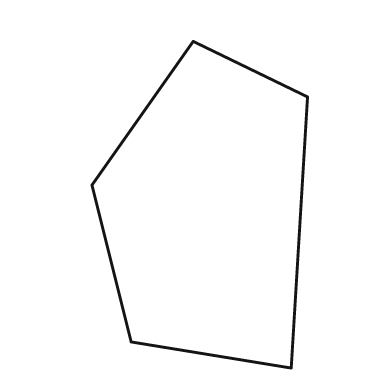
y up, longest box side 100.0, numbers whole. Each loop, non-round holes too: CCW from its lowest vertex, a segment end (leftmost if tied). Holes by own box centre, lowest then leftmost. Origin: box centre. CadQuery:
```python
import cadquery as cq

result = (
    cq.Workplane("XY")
    .moveTo(28.0, -50.0)
    .lineTo(33.0, 33.0)
    .lineTo(-2.0, 50.0)
    .lineTo(-33.0, 6.0)
    .lineTo(-21.0, -42.0)
    .close()
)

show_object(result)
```